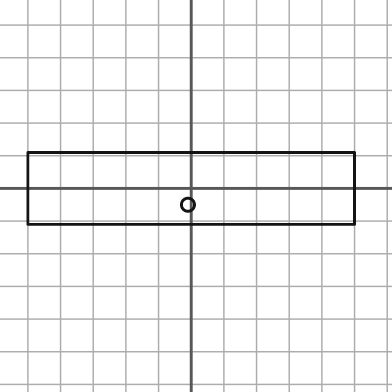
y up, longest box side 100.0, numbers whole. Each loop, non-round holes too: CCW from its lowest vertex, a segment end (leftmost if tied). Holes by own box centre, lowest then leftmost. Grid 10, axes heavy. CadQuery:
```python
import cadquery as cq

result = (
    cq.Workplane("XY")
    .moveTo(-50.0, -11.0)
    .lineTo(50.0, -11.0)
    .lineTo(50.0, 11.0)
    .lineTo(-50.0, 11.0)
    .close()
    .moveTo(-1.0, -5.0)
    .circle(2.0)
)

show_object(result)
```